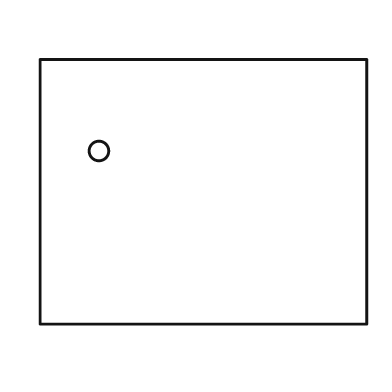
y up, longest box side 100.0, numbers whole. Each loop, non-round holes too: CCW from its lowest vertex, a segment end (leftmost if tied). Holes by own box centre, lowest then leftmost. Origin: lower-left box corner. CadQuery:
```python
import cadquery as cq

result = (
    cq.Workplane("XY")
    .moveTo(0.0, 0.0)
    .lineTo(100.0, 0.0)
    .lineTo(100.0, 81.0)
    .lineTo(0.0, 81.0)
    .close()
    .moveTo(18.0, 53.0)
    .circle(3.0)
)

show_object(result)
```